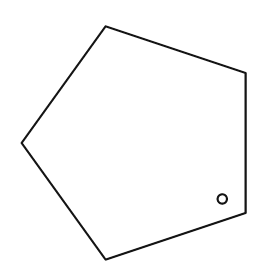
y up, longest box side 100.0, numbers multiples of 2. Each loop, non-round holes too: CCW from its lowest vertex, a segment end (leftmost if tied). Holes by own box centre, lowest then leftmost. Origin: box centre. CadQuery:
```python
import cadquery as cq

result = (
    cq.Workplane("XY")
    .moveTo(-12.0, -50.0)
    .lineTo(48.0, -30.0)
    .lineTo(48.0, 30.0)
    .lineTo(-12.0, 50.0)
    .lineTo(-48.0, 0.0)
    .close()
    .moveTo(38.0, -24.0)
    .circle(2.0)
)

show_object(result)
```